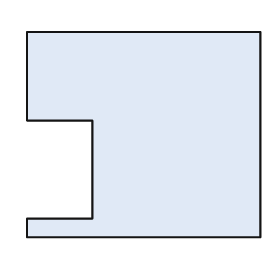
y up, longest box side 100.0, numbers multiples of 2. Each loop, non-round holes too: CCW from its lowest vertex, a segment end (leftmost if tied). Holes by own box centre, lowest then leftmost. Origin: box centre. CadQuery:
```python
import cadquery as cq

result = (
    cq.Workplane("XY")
    .moveTo(-50.0, -44.0)
    .lineTo(50.0, -44.0)
    .lineTo(50.0, 44.0)
    .lineTo(-50.0, 44.0)
    .lineTo(-50.0, 6.0)
    .lineTo(-22.0, 6.0)
    .lineTo(-22.0, -36.0)
    .lineTo(-50.0, -36.0)
    .close()
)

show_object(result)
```